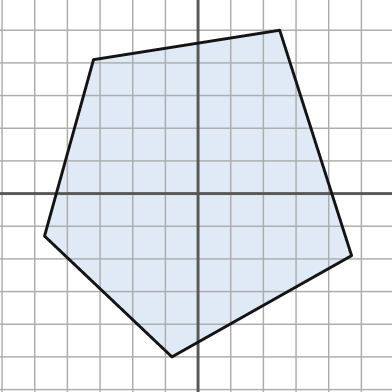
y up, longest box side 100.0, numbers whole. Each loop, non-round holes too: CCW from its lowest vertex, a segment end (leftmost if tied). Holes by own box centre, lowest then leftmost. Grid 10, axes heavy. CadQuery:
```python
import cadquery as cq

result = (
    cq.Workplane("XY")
    .moveTo(-8.0, -50.0)
    .lineTo(47.0, -19.0)
    .lineTo(25.0, 50.0)
    .lineTo(-32.0, 41.0)
    .lineTo(-47.0, -13.0)
    .close()
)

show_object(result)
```